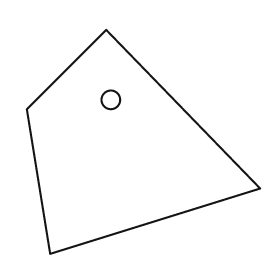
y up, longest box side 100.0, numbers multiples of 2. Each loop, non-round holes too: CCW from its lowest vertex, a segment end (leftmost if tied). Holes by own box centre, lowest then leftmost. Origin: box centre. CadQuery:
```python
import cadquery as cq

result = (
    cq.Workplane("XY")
    .moveTo(-40.0, -48.0)
    .lineTo(50.0, -20.0)
    .lineTo(-16.0, 48.0)
    .lineTo(-50.0, 14.0)
    .close()
    .moveTo(-14.0, 18.0)
    .circle(4.0)
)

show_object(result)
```